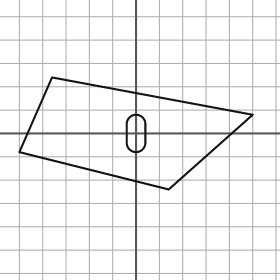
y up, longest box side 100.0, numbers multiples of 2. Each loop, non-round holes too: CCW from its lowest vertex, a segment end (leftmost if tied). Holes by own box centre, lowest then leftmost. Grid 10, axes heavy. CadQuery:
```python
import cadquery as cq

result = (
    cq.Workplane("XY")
    .moveTo(14.0, -24.0)
    .lineTo(50.0, 8.0)
    .lineTo(-36.0, 24.0)
    .lineTo(-50.0, -8.0)
    .close()
    .moveTo(-4.0, -4.0)
    .threePointArc((0.0, -8.0), (4.0, -4.0))
    .lineTo(4.0, 4.0)
    .threePointArc((0.0, 8.0), (-4.0, 4.0))
    .close()
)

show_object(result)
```